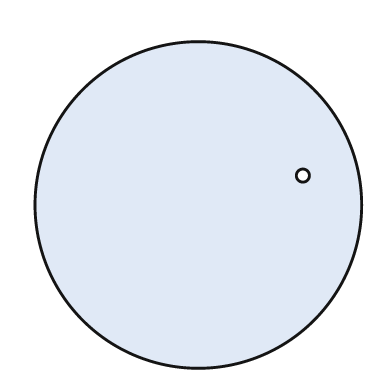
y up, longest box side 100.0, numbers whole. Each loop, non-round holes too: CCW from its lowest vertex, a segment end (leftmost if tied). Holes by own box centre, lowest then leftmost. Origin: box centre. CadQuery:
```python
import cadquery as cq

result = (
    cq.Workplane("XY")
    .moveTo(0.0, 0.0)
    .circle(50.0)
    .moveTo(32.0, 9.0)
    .circle(2.0)
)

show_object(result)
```